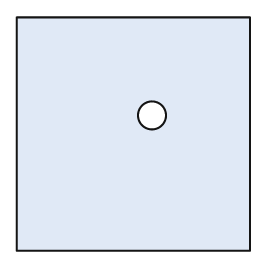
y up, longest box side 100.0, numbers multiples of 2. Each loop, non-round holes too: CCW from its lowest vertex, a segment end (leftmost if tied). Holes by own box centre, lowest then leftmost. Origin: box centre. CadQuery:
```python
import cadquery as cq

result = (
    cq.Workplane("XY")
    .moveTo(-50.0, -50.0)
    .lineTo(50.0, -50.0)
    .lineTo(50.0, 50.0)
    .lineTo(-50.0, 50.0)
    .close()
    .moveTo(8.0, 8.0)
    .circle(6.0)
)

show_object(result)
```